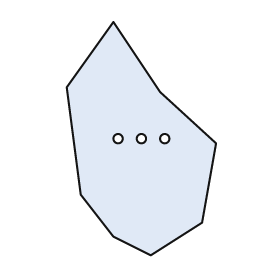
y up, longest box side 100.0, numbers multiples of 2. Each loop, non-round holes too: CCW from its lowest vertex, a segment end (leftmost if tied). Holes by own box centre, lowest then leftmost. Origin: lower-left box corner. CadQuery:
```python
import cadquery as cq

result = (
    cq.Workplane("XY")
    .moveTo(36.0, 0.0)
    .lineTo(58.0, 14.0)
    .lineTo(64.0, 48.0)
    .lineTo(40.0, 70.0)
    .lineTo(20.0, 100.0)
    .lineTo(0.0, 72.0)
    .lineTo(6.0, 26.0)
    .lineTo(20.0, 8.0)
    .close()
    .moveTo(22.0, 50.0)
    .circle(2.0)
    .moveTo(32.0, 50.0)
    .circle(2.0)
    .moveTo(42.0, 50.0)
    .circle(2.0)
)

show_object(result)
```